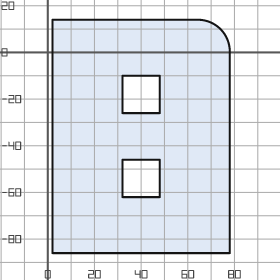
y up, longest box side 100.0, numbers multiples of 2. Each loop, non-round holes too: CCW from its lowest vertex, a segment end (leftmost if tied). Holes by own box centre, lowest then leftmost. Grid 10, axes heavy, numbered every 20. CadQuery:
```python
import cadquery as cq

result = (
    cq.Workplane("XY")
    .moveTo(2.0, -86.0)
    .lineTo(78.0, -86.0)
    .lineTo(78.0, 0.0)
    .threePointArc((74.0, 10.0), (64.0, 14.0))
    .lineTo(2.0, 14.0)
    .close()
    .moveTo(32.0, -62.0)
    .lineTo(48.0, -62.0)
    .lineTo(48.0, -46.0)
    .lineTo(32.0, -46.0)
    .close()
    .moveTo(32.0, -26.0)
    .lineTo(48.0, -26.0)
    .lineTo(48.0, -10.0)
    .lineTo(32.0, -10.0)
    .close()
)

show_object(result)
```